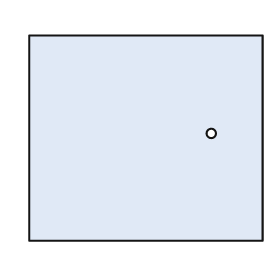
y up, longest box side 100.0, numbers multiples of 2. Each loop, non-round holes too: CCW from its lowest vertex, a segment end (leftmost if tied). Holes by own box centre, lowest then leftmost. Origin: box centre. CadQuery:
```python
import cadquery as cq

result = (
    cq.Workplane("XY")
    .moveTo(-50.0, -44.0)
    .lineTo(50.0, -44.0)
    .lineTo(50.0, 44.0)
    .lineTo(-50.0, 44.0)
    .close()
    .moveTo(28.0, 2.0)
    .circle(2.0)
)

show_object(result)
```